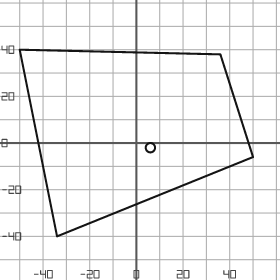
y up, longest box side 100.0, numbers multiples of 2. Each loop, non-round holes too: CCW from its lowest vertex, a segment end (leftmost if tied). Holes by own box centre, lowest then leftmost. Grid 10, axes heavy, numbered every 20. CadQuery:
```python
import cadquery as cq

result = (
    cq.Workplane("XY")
    .moveTo(-34.0, -40.0)
    .lineTo(50.0, -6.0)
    .lineTo(36.0, 38.0)
    .lineTo(-50.0, 40.0)
    .close()
    .moveTo(6.0, -2.0)
    .circle(2.0)
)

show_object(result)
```